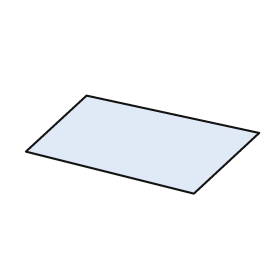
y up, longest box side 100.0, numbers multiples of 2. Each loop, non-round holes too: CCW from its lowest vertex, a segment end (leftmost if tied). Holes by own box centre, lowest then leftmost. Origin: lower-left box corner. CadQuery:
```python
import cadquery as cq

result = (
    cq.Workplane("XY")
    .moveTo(72.0, 0.0)
    .lineTo(100.0, 26.0)
    .lineTo(26.0, 42.0)
    .lineTo(0.0, 18.0)
    .close()
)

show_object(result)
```